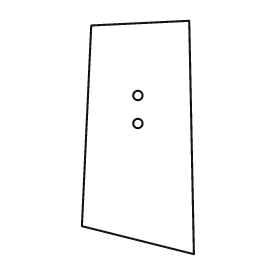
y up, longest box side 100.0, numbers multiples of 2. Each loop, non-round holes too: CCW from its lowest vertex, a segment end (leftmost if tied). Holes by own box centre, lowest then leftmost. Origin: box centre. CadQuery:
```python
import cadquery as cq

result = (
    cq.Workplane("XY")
    .moveTo(24.0, -50.0)
    .lineTo(22.0, 50.0)
    .lineTo(-20.0, 48.0)
    .lineTo(-24.0, -38.0)
    .close()
    .moveTo(0.0, 6.0)
    .circle(2.0)
    .moveTo(0.0, 18.0)
    .circle(2.0)
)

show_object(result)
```